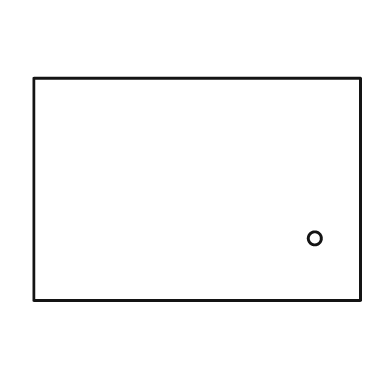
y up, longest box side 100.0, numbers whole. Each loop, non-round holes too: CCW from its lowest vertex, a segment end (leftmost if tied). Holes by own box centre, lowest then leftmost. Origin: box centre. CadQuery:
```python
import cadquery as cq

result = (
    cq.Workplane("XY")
    .moveTo(-50.0, -34.0)
    .lineTo(50.0, -34.0)
    .lineTo(50.0, 34.0)
    .lineTo(-50.0, 34.0)
    .close()
    .moveTo(36.0, -15.0)
    .circle(2.0)
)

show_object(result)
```